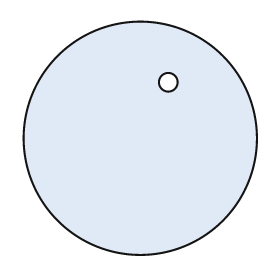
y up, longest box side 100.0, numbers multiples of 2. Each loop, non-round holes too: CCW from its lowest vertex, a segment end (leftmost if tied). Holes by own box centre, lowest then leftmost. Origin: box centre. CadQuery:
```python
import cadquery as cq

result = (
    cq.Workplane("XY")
    .moveTo(0.0, 0.0)
    .circle(50.0)
    .moveTo(12.0, 24.0)
    .circle(4.0)
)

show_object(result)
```